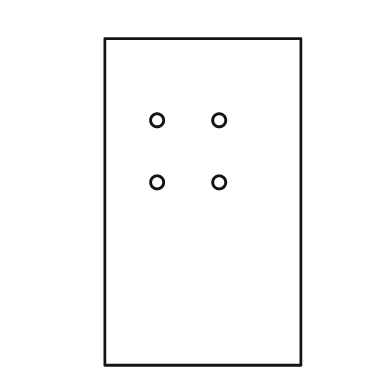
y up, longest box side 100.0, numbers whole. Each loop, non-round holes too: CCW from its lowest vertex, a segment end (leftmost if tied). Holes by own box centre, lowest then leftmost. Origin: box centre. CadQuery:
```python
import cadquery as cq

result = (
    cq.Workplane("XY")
    .moveTo(-30.0, -50.0)
    .lineTo(30.0, -50.0)
    .lineTo(30.0, 50.0)
    .lineTo(-30.0, 50.0)
    .close()
    .moveTo(-14.0, 6.0)
    .circle(2.0)
    .moveTo(5.0, 6.0)
    .circle(2.0)
    .moveTo(-14.0, 25.0)
    .circle(2.0)
    .moveTo(5.0, 25.0)
    .circle(2.0)
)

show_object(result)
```